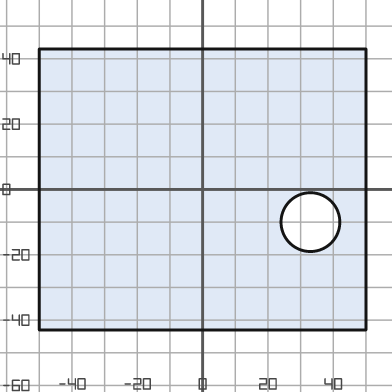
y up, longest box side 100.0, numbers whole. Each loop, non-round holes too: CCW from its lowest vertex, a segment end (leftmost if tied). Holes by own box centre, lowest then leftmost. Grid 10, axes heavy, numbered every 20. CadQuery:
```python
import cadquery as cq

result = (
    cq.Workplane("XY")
    .moveTo(-50.0, -43.0)
    .lineTo(50.0, -43.0)
    .lineTo(50.0, 43.0)
    .lineTo(-50.0, 43.0)
    .close()
    .moveTo(33.0, -10.0)
    .circle(9.0)
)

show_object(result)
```